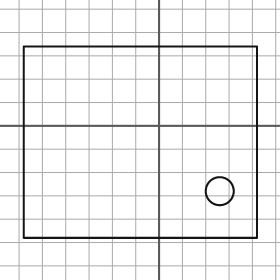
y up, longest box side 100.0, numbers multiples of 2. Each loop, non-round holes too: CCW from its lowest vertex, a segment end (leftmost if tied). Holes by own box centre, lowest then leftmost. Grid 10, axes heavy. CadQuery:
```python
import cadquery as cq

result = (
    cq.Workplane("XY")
    .moveTo(-58.0, -48.0)
    .lineTo(42.0, -48.0)
    .lineTo(42.0, 34.0)
    .lineTo(-58.0, 34.0)
    .close()
    .moveTo(26.0, -28.0)
    .circle(6.0)
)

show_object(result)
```